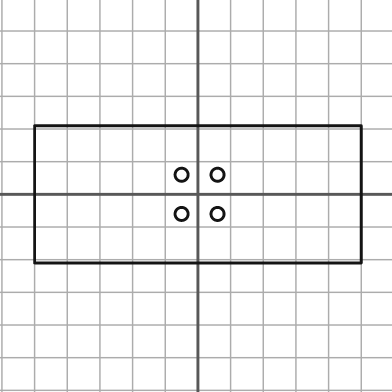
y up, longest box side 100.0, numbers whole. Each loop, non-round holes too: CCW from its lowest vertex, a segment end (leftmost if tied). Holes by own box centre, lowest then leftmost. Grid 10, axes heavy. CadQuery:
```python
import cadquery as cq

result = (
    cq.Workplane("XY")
    .moveTo(-50.0, -21.0)
    .lineTo(50.0, -21.0)
    .lineTo(50.0, 21.0)
    .lineTo(-50.0, 21.0)
    .close()
    .moveTo(-5.0, -6.0)
    .circle(2.0)
    .moveTo(6.0, -6.0)
    .circle(2.0)
    .moveTo(-5.0, 6.0)
    .circle(2.0)
    .moveTo(6.0, 6.0)
    .circle(2.0)
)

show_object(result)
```